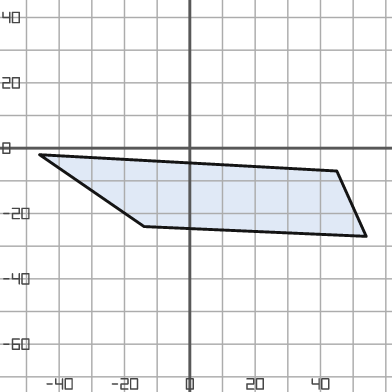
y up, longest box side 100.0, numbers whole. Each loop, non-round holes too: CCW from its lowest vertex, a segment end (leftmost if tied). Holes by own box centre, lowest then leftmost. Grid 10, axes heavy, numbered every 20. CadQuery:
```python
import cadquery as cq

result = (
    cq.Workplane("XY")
    .moveTo(54.0, -27.0)
    .lineTo(45.0, -7.0)
    .lineTo(-46.0, -2.0)
    .lineTo(-14.0, -24.0)
    .close()
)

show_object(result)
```